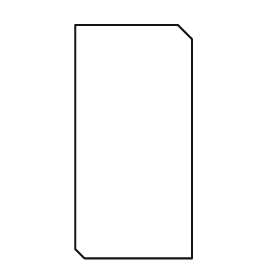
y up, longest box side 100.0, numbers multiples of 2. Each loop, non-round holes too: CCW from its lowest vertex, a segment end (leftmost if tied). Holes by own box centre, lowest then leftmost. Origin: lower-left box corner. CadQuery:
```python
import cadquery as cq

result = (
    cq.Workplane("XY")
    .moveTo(4.0, 0.0)
    .lineTo(50.0, 0.0)
    .lineTo(50.0, 94.0)
    .lineTo(44.0, 100.0)
    .lineTo(0.0, 100.0)
    .lineTo(0.0, 4.0)
    .close()
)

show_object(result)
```